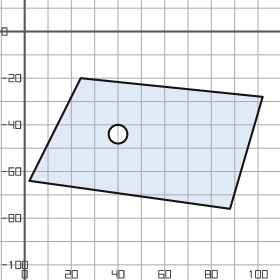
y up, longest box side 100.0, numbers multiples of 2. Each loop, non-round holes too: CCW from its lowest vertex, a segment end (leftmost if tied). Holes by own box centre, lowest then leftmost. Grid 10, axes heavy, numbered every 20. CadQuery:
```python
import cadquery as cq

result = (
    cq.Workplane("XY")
    .moveTo(88.0, -76.0)
    .lineTo(102.0, -28.0)
    .lineTo(24.0, -20.0)
    .lineTo(2.0, -64.0)
    .close()
    .moveTo(40.0, -44.0)
    .circle(4.0)
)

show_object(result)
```